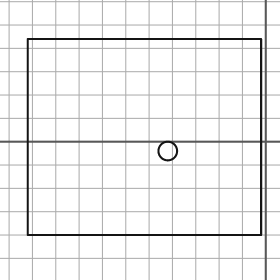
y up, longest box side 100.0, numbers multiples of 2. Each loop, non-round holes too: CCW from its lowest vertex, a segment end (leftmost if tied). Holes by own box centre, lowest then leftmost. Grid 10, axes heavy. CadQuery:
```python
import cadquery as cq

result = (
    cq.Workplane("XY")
    .moveTo(-102.0, -40.0)
    .lineTo(-2.0, -40.0)
    .lineTo(-2.0, 44.0)
    .lineTo(-102.0, 44.0)
    .close()
    .moveTo(-42.0, -4.0)
    .circle(4.0)
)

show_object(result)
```